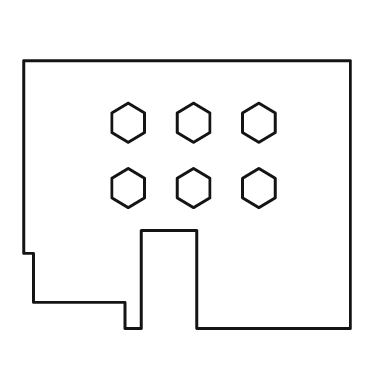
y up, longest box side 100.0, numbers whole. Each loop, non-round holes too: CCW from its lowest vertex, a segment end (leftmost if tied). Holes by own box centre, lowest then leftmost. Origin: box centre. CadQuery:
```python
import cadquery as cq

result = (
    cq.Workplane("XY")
    .moveTo(-19.0, -41.0)
    .lineTo(-14.0, -41.0)
    .lineTo(-14.0, -11.0)
    .lineTo(3.0, -11.0)
    .lineTo(3.0, -41.0)
    .lineTo(50.0, -41.0)
    .lineTo(50.0, 41.0)
    .lineTo(-50.0, 41.0)
    .lineTo(-50.0, -18.0)
    .lineTo(-47.0, -18.0)
    .lineTo(-47.0, -33.0)
    .lineTo(-19.0, -33.0)
    .close()
    .moveTo(-18.0, -4.0)
    .lineTo(-13.0, -1.0)
    .lineTo(-13.0, 5.0)
    .lineTo(-18.0, 8.0)
    .lineTo(-23.0, 5.0)
    .lineTo(-23.0, -1.0)
    .close()
    .moveTo(2.0, -4.0)
    .lineTo(7.0, -1.0)
    .lineTo(7.0, 5.0)
    .lineTo(2.0, 8.0)
    .lineTo(-3.0, 5.0)
    .lineTo(-3.0, -1.0)
    .close()
    .moveTo(22.0, -4.0)
    .lineTo(27.0, -1.0)
    .lineTo(27.0, 5.0)
    .lineTo(22.0, 8.0)
    .lineTo(17.0, 5.0)
    .lineTo(17.0, -1.0)
    .close()
    .moveTo(-18.0, 16.0)
    .lineTo(-13.0, 19.0)
    .lineTo(-13.0, 25.0)
    .lineTo(-18.0, 28.0)
    .lineTo(-23.0, 25.0)
    .lineTo(-23.0, 19.0)
    .close()
    .moveTo(2.0, 16.0)
    .lineTo(7.0, 19.0)
    .lineTo(7.0, 25.0)
    .lineTo(2.0, 28.0)
    .lineTo(-3.0, 25.0)
    .lineTo(-3.0, 19.0)
    .close()
    .moveTo(22.0, 16.0)
    .lineTo(27.0, 19.0)
    .lineTo(27.0, 25.0)
    .lineTo(22.0, 28.0)
    .lineTo(17.0, 25.0)
    .lineTo(17.0, 19.0)
    .close()
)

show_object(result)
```